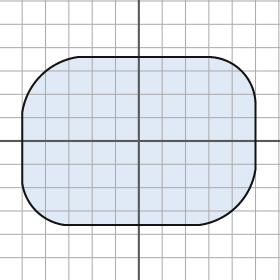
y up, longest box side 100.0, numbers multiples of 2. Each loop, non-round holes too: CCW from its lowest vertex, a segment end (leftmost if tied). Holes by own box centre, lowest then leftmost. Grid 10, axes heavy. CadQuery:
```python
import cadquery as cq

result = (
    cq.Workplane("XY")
    .moveTo(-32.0, -36.0)
    .lineTo(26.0, -36.0)
    .threePointArc((42.0, -28.0), (50.0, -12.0))
    .lineTo(50.0, 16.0)
    .threePointArc((44.0, 30.0), (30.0, 36.0))
    .lineTo(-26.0, 36.0)
    .threePointArc((-42.0, 28.0), (-50.0, 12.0))
    .lineTo(-50.0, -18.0)
    .threePointArc((-44.0, -30.0), (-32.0, -36.0))
    .close()
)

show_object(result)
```